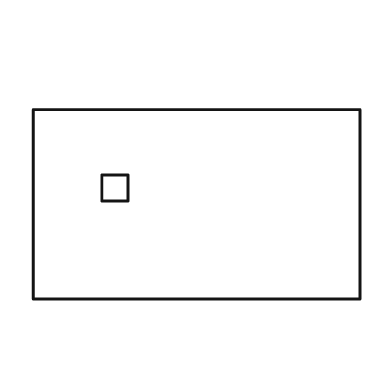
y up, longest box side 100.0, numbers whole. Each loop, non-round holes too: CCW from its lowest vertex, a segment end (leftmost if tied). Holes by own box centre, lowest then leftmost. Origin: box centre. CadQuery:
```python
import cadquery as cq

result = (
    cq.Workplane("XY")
    .moveTo(-50.0, -29.0)
    .lineTo(50.0, -29.0)
    .lineTo(50.0, 29.0)
    .lineTo(-50.0, 29.0)
    .close()
    .moveTo(-29.0, 1.0)
    .lineTo(-21.0, 1.0)
    .lineTo(-21.0, 9.0)
    .lineTo(-29.0, 9.0)
    .close()
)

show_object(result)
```